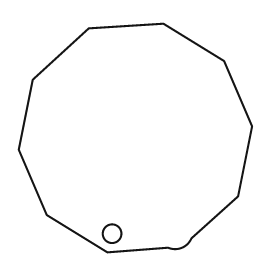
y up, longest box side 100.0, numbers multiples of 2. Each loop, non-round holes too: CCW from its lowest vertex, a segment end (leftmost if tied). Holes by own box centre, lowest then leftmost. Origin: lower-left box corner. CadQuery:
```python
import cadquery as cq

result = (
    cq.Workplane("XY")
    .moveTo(38.0, 0.0)
    .lineTo(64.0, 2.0)
    .threePointArc((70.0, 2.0), (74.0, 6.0))
    .lineTo(94.0, 24.0)
    .lineTo(100.0, 54.0)
    .lineTo(88.0, 82.0)
    .lineTo(62.0, 98.0)
    .lineTo(30.0, 96.0)
    .lineTo(6.0, 74.0)
    .lineTo(0.0, 44.0)
    .lineTo(12.0, 16.0)
    .close()
    .moveTo(40.0, 8.0)
    .circle(4.0)
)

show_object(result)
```